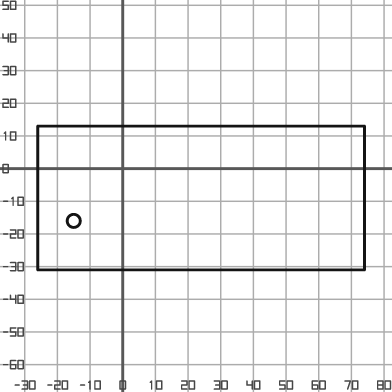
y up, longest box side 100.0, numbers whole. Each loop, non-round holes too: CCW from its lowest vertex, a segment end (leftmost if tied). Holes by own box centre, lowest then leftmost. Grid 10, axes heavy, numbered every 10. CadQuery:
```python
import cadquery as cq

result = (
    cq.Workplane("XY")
    .moveTo(-26.0, -31.0)
    .lineTo(74.0, -31.0)
    .lineTo(74.0, 13.0)
    .lineTo(-26.0, 13.0)
    .close()
    .moveTo(-15.0, -16.0)
    .circle(2.0)
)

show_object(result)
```